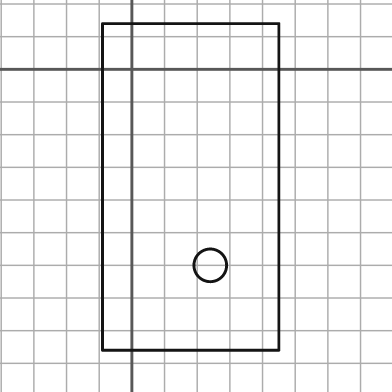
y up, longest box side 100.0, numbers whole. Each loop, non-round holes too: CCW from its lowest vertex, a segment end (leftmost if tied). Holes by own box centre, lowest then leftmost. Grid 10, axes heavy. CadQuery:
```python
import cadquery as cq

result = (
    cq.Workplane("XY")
    .moveTo(-9.0, -86.0)
    .lineTo(45.0, -86.0)
    .lineTo(45.0, 14.0)
    .lineTo(-9.0, 14.0)
    .close()
    .moveTo(24.0, -60.0)
    .circle(5.0)
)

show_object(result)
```